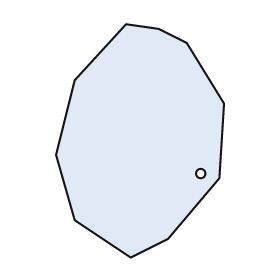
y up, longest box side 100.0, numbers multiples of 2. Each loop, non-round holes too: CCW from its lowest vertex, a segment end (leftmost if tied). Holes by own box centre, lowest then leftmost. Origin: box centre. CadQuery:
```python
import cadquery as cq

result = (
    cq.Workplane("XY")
    .moveTo(-4.0, -50.0)
    .lineTo(12.0, -42.0)
    .lineTo(34.0, -16.0)
    .lineTo(36.0, 16.0)
    .lineTo(20.0, 42.0)
    .lineTo(8.0, 48.0)
    .lineTo(-6.0, 50.0)
    .lineTo(-28.0, 26.0)
    .lineTo(-36.0, -6.0)
    .lineTo(-28.0, -34.0)
    .close()
    .moveTo(26.0, -14.0)
    .circle(2.0)
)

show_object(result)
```